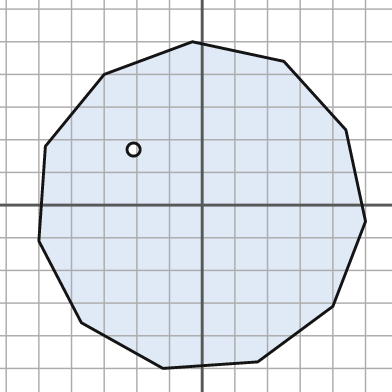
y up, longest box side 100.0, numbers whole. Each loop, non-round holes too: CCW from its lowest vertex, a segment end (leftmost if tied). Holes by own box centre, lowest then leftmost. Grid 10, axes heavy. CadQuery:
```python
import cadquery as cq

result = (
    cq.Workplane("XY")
    .moveTo(-12.0, -50.0)
    .lineTo(17.0, -48.0)
    .lineTo(40.0, -31.0)
    .lineTo(50.0, -5.0)
    .lineTo(44.0, 23.0)
    .lineTo(25.0, 44.0)
    .lineTo(-3.0, 50.0)
    .lineTo(-30.0, 40.0)
    .lineTo(-48.0, 18.0)
    .lineTo(-50.0, -11.0)
    .lineTo(-37.0, -36.0)
    .close()
    .moveTo(-21.0, 17.0)
    .circle(2.0)
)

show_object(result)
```